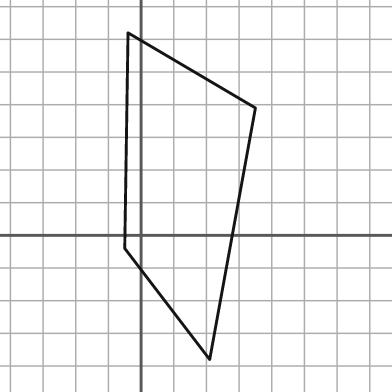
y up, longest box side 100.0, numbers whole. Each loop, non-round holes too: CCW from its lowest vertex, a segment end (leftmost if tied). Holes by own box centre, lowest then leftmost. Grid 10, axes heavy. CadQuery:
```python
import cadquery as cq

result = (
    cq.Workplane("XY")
    .moveTo(21.0, -38.0)
    .lineTo(35.0, 39.0)
    .lineTo(-4.0, 62.0)
    .lineTo(-5.0, -4.0)
    .close()
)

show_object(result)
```